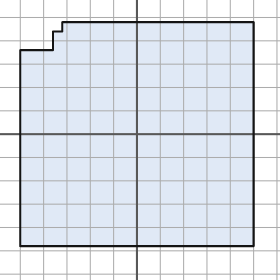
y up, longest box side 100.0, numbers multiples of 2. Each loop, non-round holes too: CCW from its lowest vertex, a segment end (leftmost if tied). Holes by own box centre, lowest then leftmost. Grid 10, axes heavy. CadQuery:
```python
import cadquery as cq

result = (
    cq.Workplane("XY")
    .moveTo(-50.0, -48.0)
    .lineTo(50.0, -48.0)
    .lineTo(50.0, 48.0)
    .lineTo(-32.0, 48.0)
    .lineTo(-32.0, 44.0)
    .lineTo(-36.0, 44.0)
    .lineTo(-36.0, 36.0)
    .lineTo(-50.0, 36.0)
    .close()
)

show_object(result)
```